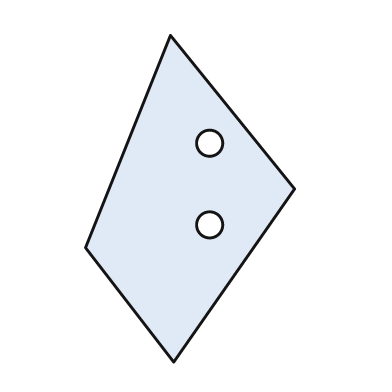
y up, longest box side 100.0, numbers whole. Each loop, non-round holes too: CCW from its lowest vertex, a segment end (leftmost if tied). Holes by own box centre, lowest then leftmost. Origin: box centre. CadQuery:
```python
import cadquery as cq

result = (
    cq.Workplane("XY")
    .moveTo(-5.0, -50.0)
    .lineTo(32.0, 3.0)
    .lineTo(-6.0, 50.0)
    .lineTo(-32.0, -15.0)
    .close()
    .moveTo(6.0, -8.0)
    .circle(4.0)
    .moveTo(6.0, 17.0)
    .circle(4.0)
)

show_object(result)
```